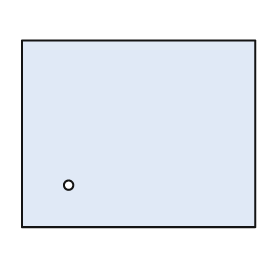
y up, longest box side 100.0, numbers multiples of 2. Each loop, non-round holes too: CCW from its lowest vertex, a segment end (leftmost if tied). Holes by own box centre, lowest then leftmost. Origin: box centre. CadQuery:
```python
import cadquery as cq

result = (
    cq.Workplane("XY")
    .moveTo(-50.0, -40.0)
    .lineTo(50.0, -40.0)
    .lineTo(50.0, 40.0)
    .lineTo(-50.0, 40.0)
    .close()
    .moveTo(-30.0, -22.0)
    .circle(2.0)
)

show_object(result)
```